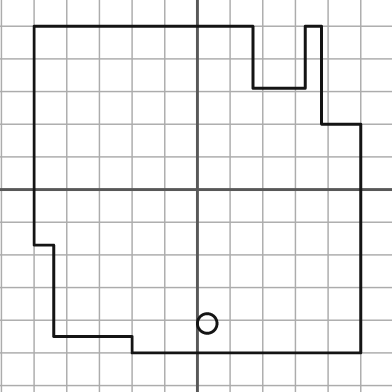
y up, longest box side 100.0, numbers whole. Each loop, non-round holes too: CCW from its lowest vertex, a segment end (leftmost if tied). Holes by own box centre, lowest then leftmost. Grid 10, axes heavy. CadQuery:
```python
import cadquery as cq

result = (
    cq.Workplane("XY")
    .moveTo(-20.0, -50.0)
    .lineTo(50.0, -50.0)
    .lineTo(50.0, 20.0)
    .lineTo(38.0, 20.0)
    .lineTo(38.0, 50.0)
    .lineTo(33.0, 50.0)
    .lineTo(33.0, 31.0)
    .lineTo(17.0, 31.0)
    .lineTo(17.0, 50.0)
    .lineTo(-50.0, 50.0)
    .lineTo(-50.0, -17.0)
    .lineTo(-44.0, -17.0)
    .lineTo(-44.0, -45.0)
    .lineTo(-20.0, -45.0)
    .close()
    .moveTo(3.0, -41.0)
    .circle(3.0)
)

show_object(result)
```